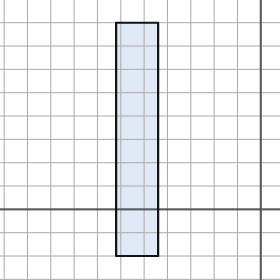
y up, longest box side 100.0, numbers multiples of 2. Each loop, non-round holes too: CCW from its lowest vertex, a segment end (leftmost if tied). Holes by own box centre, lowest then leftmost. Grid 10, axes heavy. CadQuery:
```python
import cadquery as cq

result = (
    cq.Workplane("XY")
    .moveTo(-62.0, -20.0)
    .lineTo(-44.0, -20.0)
    .lineTo(-44.0, 80.0)
    .lineTo(-62.0, 80.0)
    .close()
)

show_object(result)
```